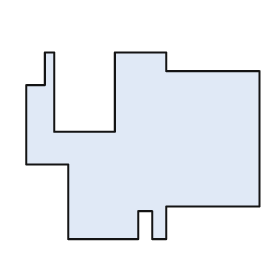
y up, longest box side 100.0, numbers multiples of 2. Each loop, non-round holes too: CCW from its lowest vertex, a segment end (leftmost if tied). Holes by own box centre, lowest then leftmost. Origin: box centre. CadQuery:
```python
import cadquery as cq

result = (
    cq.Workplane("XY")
    .moveTo(-32.0, -40.0)
    .lineTo(-2.0, -40.0)
    .lineTo(-2.0, -28.0)
    .lineTo(4.0, -28.0)
    .lineTo(4.0, -40.0)
    .lineTo(10.0, -40.0)
    .lineTo(10.0, -26.0)
    .lineTo(50.0, -26.0)
    .lineTo(50.0, 32.0)
    .lineTo(10.0, 32.0)
    .lineTo(10.0, 40.0)
    .lineTo(-12.0, 40.0)
    .lineTo(-12.0, 6.0)
    .lineTo(-38.0, 6.0)
    .lineTo(-38.0, 40.0)
    .lineTo(-42.0, 40.0)
    .lineTo(-42.0, 26.0)
    .lineTo(-50.0, 26.0)
    .lineTo(-50.0, -8.0)
    .lineTo(-32.0, -8.0)
    .close()
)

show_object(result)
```